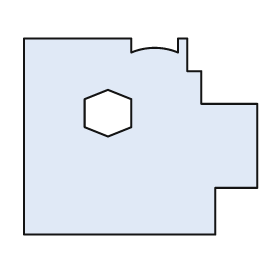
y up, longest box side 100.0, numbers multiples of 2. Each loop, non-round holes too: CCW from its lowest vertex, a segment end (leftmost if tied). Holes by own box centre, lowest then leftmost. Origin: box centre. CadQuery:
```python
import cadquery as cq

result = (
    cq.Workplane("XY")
    .moveTo(-50.0, -42.0)
    .lineTo(32.0, -42.0)
    .lineTo(32.0, -22.0)
    .lineTo(50.0, -22.0)
    .lineTo(50.0, 14.0)
    .lineTo(26.0, 14.0)
    .lineTo(26.0, 28.0)
    .lineTo(20.0, 28.0)
    .lineTo(20.0, 42.0)
    .lineTo(16.0, 42.0)
    .lineTo(16.0, 36.0)
    .threePointArc((6.0, 38.0), (-4.0, 36.0))
    .lineTo(-4.0, 42.0)
    .lineTo(-50.0, 42.0)
    .close()
    .moveTo(-14.0, 0.0)
    .lineTo(-4.0, 4.0)
    .lineTo(-4.0, 16.0)
    .lineTo(-14.0, 20.0)
    .lineTo(-24.0, 16.0)
    .lineTo(-24.0, 4.0)
    .close()
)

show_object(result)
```